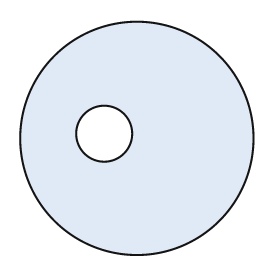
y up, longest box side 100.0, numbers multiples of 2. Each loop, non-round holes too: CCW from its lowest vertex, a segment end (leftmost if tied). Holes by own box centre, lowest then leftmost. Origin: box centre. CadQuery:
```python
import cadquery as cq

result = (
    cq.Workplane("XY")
    .moveTo(0.0, 0.0)
    .circle(50.0)
    .moveTo(-14.0, 2.0)
    .circle(12.0)
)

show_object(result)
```